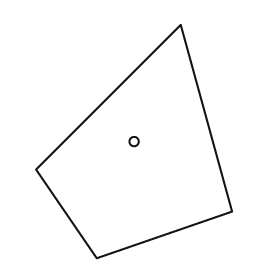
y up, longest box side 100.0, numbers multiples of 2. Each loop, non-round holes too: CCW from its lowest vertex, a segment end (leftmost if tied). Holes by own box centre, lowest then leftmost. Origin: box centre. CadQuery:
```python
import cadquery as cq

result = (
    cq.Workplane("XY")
    .moveTo(-16.0, -50.0)
    .lineTo(42.0, -30.0)
    .lineTo(20.0, 50.0)
    .lineTo(-42.0, -12.0)
    .close()
    .moveTo(0.0, 0.0)
    .circle(2.0)
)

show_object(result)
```